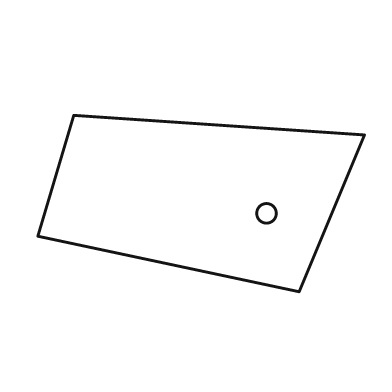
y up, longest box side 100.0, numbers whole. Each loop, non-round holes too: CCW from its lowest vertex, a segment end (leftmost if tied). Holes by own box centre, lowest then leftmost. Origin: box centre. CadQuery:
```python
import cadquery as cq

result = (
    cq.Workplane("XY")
    .moveTo(30.0, -27.0)
    .lineTo(50.0, 21.0)
    .lineTo(-39.0, 27.0)
    .lineTo(-50.0, -10.0)
    .close()
    .moveTo(20.0, -3.0)
    .circle(3.0)
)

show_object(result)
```